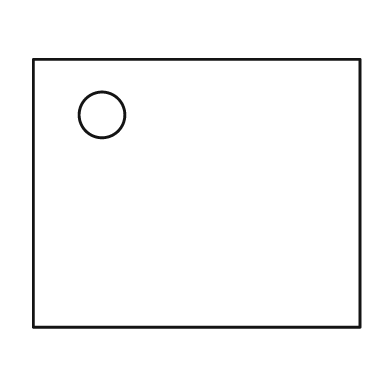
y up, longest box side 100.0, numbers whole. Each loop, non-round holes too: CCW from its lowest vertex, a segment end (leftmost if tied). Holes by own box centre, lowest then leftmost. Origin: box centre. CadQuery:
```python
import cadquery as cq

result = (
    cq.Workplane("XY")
    .moveTo(-50.0, -41.0)
    .lineTo(50.0, -41.0)
    .lineTo(50.0, 41.0)
    .lineTo(-50.0, 41.0)
    .close()
    .moveTo(-29.0, 24.0)
    .circle(7.0)
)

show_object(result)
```